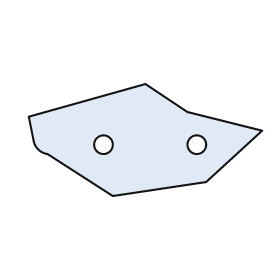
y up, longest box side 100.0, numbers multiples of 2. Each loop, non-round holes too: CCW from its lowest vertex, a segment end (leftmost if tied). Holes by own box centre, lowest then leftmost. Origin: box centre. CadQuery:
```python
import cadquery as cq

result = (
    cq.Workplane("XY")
    .moveTo(-14.0, -24.0)
    .lineTo(26.0, -18.0)
    .lineTo(50.0, 4.0)
    .lineTo(18.0, 12.0)
    .lineTo(0.0, 24.0)
    .lineTo(-50.0, 10.0)
    .lineTo(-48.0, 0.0)
    .threePointArc((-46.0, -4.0), (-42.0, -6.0))
    .close()
    .moveTo(-18.0, -2.0)
    .circle(4.0)
    .moveTo(22.0, -2.0)
    .circle(4.0)
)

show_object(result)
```